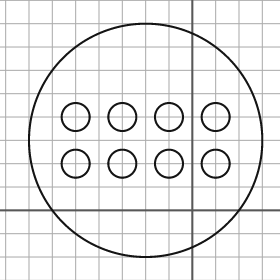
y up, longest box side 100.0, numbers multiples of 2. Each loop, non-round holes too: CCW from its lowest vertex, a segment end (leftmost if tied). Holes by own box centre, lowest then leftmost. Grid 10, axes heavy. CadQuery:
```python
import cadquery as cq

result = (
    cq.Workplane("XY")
    .moveTo(-20.0, 30.0)
    .circle(50.0)
    .moveTo(-50.0, 20.0)
    .circle(6.0)
    .moveTo(-30.0, 20.0)
    .circle(6.0)
    .moveTo(-10.0, 20.0)
    .circle(6.0)
    .moveTo(10.0, 20.0)
    .circle(6.0)
    .moveTo(-50.0, 40.0)
    .circle(6.0)
    .moveTo(-30.0, 40.0)
    .circle(6.0)
    .moveTo(-10.0, 40.0)
    .circle(6.0)
    .moveTo(10.0, 40.0)
    .circle(6.0)
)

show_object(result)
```